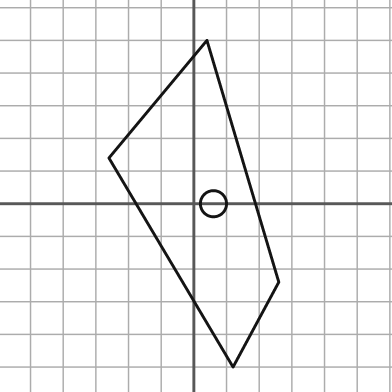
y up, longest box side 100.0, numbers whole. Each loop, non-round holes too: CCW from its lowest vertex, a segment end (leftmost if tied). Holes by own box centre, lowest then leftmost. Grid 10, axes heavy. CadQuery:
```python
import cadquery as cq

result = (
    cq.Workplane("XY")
    .moveTo(12.0, -50.0)
    .lineTo(26.0, -24.0)
    .lineTo(4.0, 50.0)
    .lineTo(-26.0, 14.0)
    .close()
    .moveTo(6.0, 0.0)
    .circle(4.0)
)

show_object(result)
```